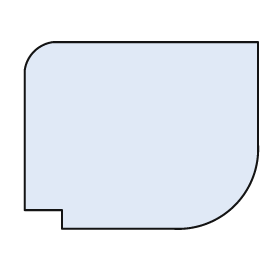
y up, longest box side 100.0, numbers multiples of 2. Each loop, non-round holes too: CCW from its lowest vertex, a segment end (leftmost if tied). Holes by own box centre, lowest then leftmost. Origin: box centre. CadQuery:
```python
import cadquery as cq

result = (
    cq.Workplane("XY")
    .moveTo(-34.0, -40.0)
    .lineTo(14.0, -40.0)
    .threePointArc((40.0, -30.0), (50.0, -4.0))
    .lineTo(50.0, 40.0)
    .lineTo(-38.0, 40.0)
    .threePointArc((-46.0, 36.0), (-50.0, 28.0))
    .lineTo(-50.0, -32.0)
    .lineTo(-34.0, -32.0)
    .close()
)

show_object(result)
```